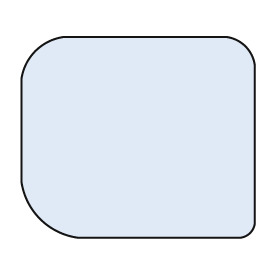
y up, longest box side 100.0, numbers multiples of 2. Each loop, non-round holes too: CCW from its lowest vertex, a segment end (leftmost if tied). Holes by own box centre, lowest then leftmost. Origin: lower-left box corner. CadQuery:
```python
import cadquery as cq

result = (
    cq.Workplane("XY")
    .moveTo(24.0, 0.0)
    .lineTo(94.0, 0.0)
    .threePointArc((98.0, 2.0), (100.0, 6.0))
    .lineTo(100.0, 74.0)
    .threePointArc((96.0, 82.0), (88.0, 86.0))
    .lineTo(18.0, 86.0)
    .threePointArc((6.0, 80.0), (0.0, 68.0))
    .lineTo(0.0, 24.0)
    .threePointArc((8.0, 8.0), (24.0, 0.0))
    .close()
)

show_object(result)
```